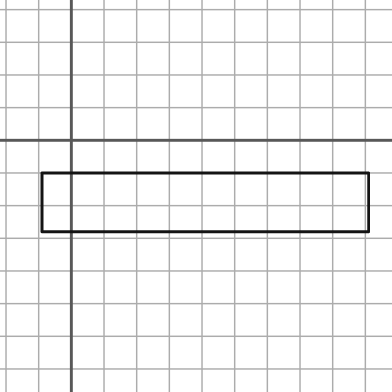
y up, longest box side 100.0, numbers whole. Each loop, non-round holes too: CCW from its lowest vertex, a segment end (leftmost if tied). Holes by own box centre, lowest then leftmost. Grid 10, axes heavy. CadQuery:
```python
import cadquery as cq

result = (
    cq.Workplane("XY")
    .moveTo(-9.0, -28.0)
    .lineTo(91.0, -28.0)
    .lineTo(91.0, -10.0)
    .lineTo(-9.0, -10.0)
    .close()
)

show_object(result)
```